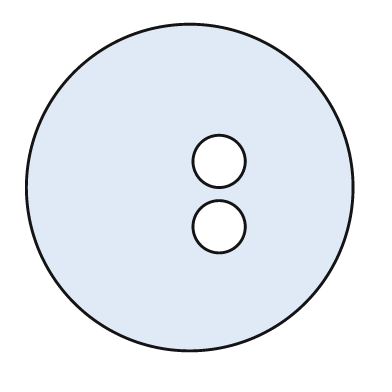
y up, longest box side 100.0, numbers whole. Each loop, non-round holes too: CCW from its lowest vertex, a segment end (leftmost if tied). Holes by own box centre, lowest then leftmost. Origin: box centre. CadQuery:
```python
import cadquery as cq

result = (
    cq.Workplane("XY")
    .moveTo(0.0, 0.0)
    .circle(50.0)
    .moveTo(9.0, -12.0)
    .circle(8.0)
    .moveTo(9.0, 8.0)
    .circle(8.0)
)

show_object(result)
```